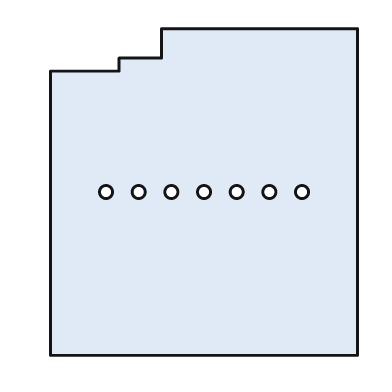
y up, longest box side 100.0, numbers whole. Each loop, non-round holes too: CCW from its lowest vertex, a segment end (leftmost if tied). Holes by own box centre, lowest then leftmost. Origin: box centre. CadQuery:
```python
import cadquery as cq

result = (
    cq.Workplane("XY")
    .moveTo(-47.0, -50.0)
    .lineTo(47.0, -50.0)
    .lineTo(47.0, 50.0)
    .lineTo(-13.0, 50.0)
    .lineTo(-13.0, 41.0)
    .lineTo(-26.0, 41.0)
    .lineTo(-26.0, 37.0)
    .lineTo(-47.0, 37.0)
    .close()
    .moveTo(-30.0, 0.0)
    .circle(2.0)
    .moveTo(-20.0, 0.0)
    .circle(2.0)
    .moveTo(-10.0, 0.0)
    .circle(2.0)
    .moveTo(0.0, 0.0)
    .circle(2.0)
    .moveTo(10.0, 0.0)
    .circle(2.0)
    .moveTo(20.0, 0.0)
    .circle(2.0)
    .moveTo(30.0, 0.0)
    .circle(2.0)
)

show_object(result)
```